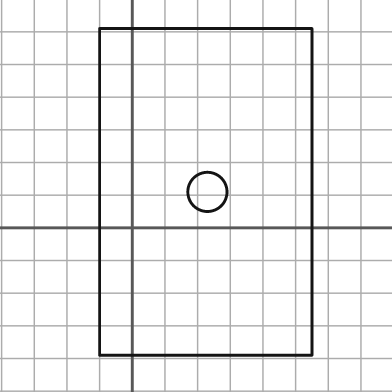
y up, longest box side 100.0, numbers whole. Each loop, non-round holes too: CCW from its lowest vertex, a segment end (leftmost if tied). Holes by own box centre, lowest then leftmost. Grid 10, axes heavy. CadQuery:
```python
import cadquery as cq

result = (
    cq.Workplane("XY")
    .moveTo(-10.0, -39.0)
    .lineTo(55.0, -39.0)
    .lineTo(55.0, 61.0)
    .lineTo(-10.0, 61.0)
    .close()
    .moveTo(23.0, 11.0)
    .circle(6.0)
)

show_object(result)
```